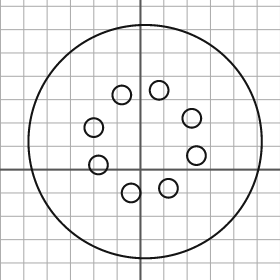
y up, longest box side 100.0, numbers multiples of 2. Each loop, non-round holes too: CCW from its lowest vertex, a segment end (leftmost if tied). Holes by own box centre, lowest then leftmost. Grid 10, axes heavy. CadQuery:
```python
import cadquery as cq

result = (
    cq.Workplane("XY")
    .moveTo(2.0, 12.0)
    .circle(50.0)
    .moveTo(-4.0, -10.0)
    .circle(4.0)
    .moveTo(12.0, -8.0)
    .circle(4.0)
    .moveTo(-18.0, 2.0)
    .circle(4.0)
    .moveTo(24.0, 6.0)
    .circle(4.0)
    .moveTo(-20.0, 18.0)
    .circle(4.0)
    .moveTo(22.0, 22.0)
    .circle(4.0)
    .moveTo(-8.0, 32.0)
    .circle(4.0)
    .moveTo(8.0, 34.0)
    .circle(4.0)
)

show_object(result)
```